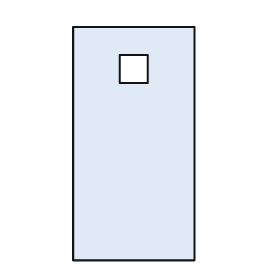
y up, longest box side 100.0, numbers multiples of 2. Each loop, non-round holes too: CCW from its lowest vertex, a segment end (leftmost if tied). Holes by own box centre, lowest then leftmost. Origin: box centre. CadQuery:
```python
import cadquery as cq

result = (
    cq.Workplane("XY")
    .moveTo(-26.0, -50.0)
    .lineTo(26.0, -50.0)
    .lineTo(26.0, 50.0)
    .lineTo(-26.0, 50.0)
    .close()
    .moveTo(-6.0, 26.0)
    .lineTo(6.0, 26.0)
    .lineTo(6.0, 38.0)
    .lineTo(-6.0, 38.0)
    .close()
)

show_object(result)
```